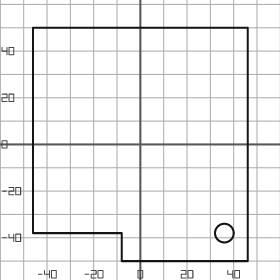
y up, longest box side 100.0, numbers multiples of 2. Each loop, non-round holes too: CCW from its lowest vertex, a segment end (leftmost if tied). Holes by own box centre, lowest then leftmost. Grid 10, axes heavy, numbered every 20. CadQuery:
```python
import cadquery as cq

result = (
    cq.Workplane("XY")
    .moveTo(-8.0, -50.0)
    .lineTo(46.0, -50.0)
    .lineTo(46.0, 50.0)
    .lineTo(-46.0, 50.0)
    .lineTo(-46.0, -38.0)
    .lineTo(-8.0, -38.0)
    .close()
    .moveTo(36.0, -38.0)
    .circle(4.0)
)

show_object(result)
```